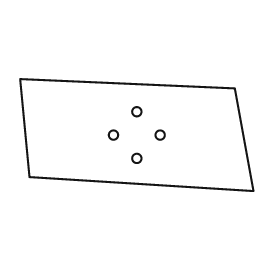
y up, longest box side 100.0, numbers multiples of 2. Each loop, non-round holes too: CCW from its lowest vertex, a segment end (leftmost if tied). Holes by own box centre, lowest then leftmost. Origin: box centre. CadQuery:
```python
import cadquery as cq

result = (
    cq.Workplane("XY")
    .moveTo(50.0, -24.0)
    .lineTo(42.0, 20.0)
    .lineTo(-50.0, 24.0)
    .lineTo(-46.0, -18.0)
    .close()
    .moveTo(0.0, -10.0)
    .circle(2.0)
    .moveTo(-10.0, 0.0)
    .circle(2.0)
    .moveTo(10.0, 0.0)
    .circle(2.0)
    .moveTo(0.0, 10.0)
    .circle(2.0)
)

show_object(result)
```